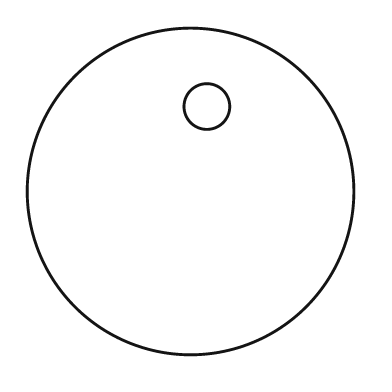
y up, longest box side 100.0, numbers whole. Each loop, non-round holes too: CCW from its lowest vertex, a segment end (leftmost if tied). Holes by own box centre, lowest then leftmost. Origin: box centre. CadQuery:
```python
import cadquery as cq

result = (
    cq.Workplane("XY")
    .moveTo(0.0, 0.0)
    .circle(50.0)
    .moveTo(5.0, 26.0)
    .circle(7.0)
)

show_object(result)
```